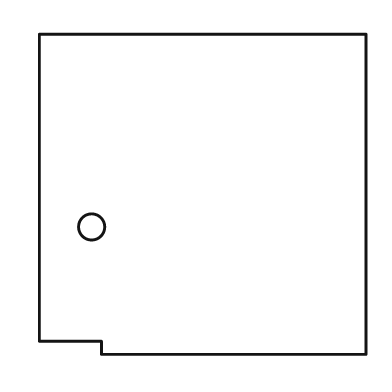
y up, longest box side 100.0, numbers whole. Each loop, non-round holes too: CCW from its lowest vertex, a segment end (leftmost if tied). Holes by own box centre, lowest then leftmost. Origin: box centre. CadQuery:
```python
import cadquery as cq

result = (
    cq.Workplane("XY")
    .moveTo(-31.0, -49.0)
    .lineTo(50.0, -49.0)
    .lineTo(50.0, 49.0)
    .lineTo(-50.0, 49.0)
    .lineTo(-50.0, -45.0)
    .lineTo(-31.0, -45.0)
    .close()
    .moveTo(-34.0, -10.0)
    .circle(4.0)
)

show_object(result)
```